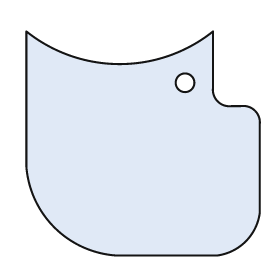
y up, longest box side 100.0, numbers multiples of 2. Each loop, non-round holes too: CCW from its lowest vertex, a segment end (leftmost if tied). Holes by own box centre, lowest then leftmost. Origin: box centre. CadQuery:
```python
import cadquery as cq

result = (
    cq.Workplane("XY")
    .moveTo(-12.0, -48.0)
    .lineTo(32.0, -48.0)
    .threePointArc((44.0, -42.0), (50.0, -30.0))
    .lineTo(50.0, 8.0)
    .threePointArc((48.0, 14.0), (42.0, 16.0))
    .lineTo(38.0, 16.0)
    .threePointArc((32.0, 18.0), (30.0, 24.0))
    .lineTo(30.0, 48.0)
    .threePointArc((-10.0, 34.0), (-50.0, 48.0))
    .lineTo(-50.0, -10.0)
    .threePointArc((-38.0, -36.0), (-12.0, -48.0))
    .close()
    .moveTo(18.0, 26.0)
    .circle(4.0)
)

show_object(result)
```